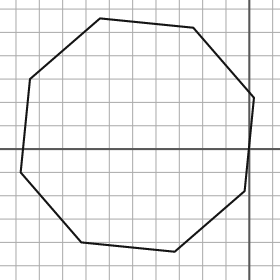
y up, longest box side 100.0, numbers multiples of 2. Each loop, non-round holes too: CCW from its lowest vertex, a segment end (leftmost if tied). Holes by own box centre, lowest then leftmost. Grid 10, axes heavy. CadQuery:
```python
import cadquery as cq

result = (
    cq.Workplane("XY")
    .moveTo(-32.0, -44.0)
    .lineTo(-2.0, -18.0)
    .lineTo(2.0, 22.0)
    .lineTo(-24.0, 52.0)
    .lineTo(-64.0, 56.0)
    .lineTo(-94.0, 30.0)
    .lineTo(-98.0, -10.0)
    .lineTo(-72.0, -40.0)
    .close()
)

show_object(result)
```